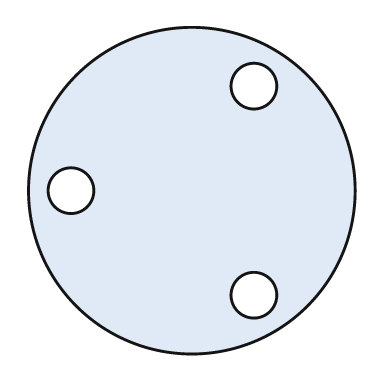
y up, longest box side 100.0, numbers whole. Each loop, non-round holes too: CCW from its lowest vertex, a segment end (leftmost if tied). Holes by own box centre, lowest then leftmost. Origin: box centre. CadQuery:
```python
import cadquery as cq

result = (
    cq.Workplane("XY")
    .moveTo(0.0, 0.0)
    .circle(50.0)
    .moveTo(19.0, -32.0)
    .circle(7.0)
    .moveTo(-37.0, 0.0)
    .circle(7.0)
    .moveTo(19.0, 32.0)
    .circle(7.0)
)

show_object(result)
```